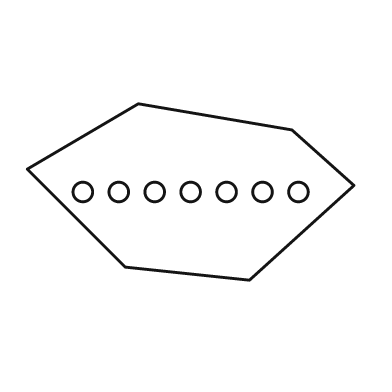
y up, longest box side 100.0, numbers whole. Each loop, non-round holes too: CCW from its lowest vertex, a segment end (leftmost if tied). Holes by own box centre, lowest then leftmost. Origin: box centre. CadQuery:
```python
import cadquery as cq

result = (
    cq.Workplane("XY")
    .moveTo(18.0, -27.0)
    .lineTo(50.0, 2.0)
    .lineTo(31.0, 19.0)
    .lineTo(-16.0, 27.0)
    .lineTo(-50.0, 7.0)
    .lineTo(-20.0, -23.0)
    .close()
    .moveTo(-33.0, 0.0)
    .circle(3.0)
    .moveTo(-22.0, 0.0)
    .circle(3.0)
    .moveTo(-11.0, 0.0)
    .circle(3.0)
    .moveTo(0.0, 0.0)
    .circle(3.0)
    .moveTo(11.0, 0.0)
    .circle(3.0)
    .moveTo(22.0, 0.0)
    .circle(3.0)
    .moveTo(33.0, 0.0)
    .circle(3.0)
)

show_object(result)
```